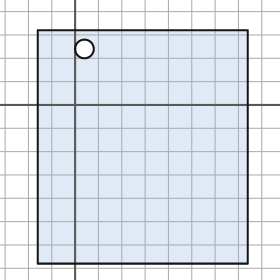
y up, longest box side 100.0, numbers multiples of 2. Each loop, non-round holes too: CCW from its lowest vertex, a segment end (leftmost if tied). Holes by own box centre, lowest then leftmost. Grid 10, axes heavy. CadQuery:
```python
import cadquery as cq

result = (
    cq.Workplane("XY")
    .moveTo(-16.0, -68.0)
    .lineTo(74.0, -68.0)
    .lineTo(74.0, 32.0)
    .lineTo(-16.0, 32.0)
    .close()
    .moveTo(4.0, 24.0)
    .circle(4.0)
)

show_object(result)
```